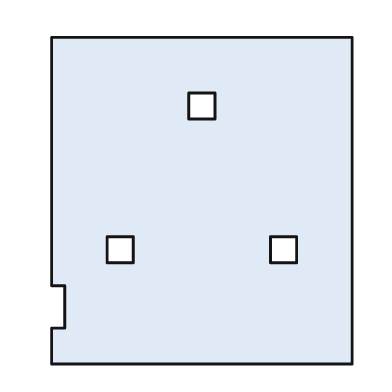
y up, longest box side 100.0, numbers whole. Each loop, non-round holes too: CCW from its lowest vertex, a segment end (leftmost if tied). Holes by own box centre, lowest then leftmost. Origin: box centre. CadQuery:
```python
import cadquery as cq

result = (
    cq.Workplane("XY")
    .moveTo(-46.0, -50.0)
    .lineTo(46.0, -50.0)
    .lineTo(46.0, 50.0)
    .lineTo(-46.0, 50.0)
    .lineTo(-46.0, -26.0)
    .lineTo(-42.0, -26.0)
    .lineTo(-42.0, -39.0)
    .lineTo(-46.0, -39.0)
    .close()
    .moveTo(-29.0, -19.0)
    .lineTo(-21.0, -19.0)
    .lineTo(-21.0, -11.0)
    .lineTo(-29.0, -11.0)
    .close()
    .moveTo(21.0, -19.0)
    .lineTo(29.0, -19.0)
    .lineTo(29.0, -11.0)
    .lineTo(21.0, -11.0)
    .close()
    .moveTo(-4.0, 25.0)
    .lineTo(4.0, 25.0)
    .lineTo(4.0, 33.0)
    .lineTo(-4.0, 33.0)
    .close()
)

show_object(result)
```